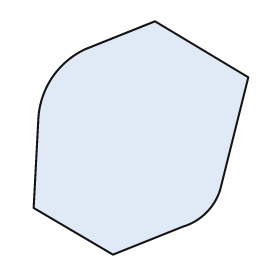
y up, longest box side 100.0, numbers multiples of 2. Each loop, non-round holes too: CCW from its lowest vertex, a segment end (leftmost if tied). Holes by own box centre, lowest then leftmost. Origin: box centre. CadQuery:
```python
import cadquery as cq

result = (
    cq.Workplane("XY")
    .moveTo(-12.0, -50.0)
    .lineTo(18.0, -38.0)
    .threePointArc((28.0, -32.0), (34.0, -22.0))
    .lineTo(46.0, 26.0)
    .lineTo(6.0, 50.0)
    .lineTo(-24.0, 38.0)
    .threePointArc((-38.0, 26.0), (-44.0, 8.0))
    .lineTo(-46.0, -30.0)
    .close()
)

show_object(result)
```